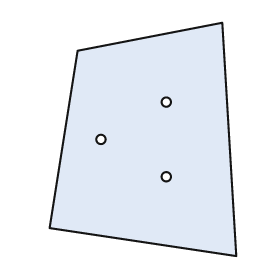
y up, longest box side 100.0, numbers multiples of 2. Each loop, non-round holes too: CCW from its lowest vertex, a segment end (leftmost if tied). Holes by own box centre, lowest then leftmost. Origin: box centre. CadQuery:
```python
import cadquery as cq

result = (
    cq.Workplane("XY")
    .moveTo(40.0, -50.0)
    .lineTo(34.0, 50.0)
    .lineTo(-28.0, 38.0)
    .lineTo(-40.0, -38.0)
    .close()
    .moveTo(10.0, -16.0)
    .circle(2.0)
    .moveTo(-18.0, 0.0)
    .circle(2.0)
    .moveTo(10.0, 16.0)
    .circle(2.0)
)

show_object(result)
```